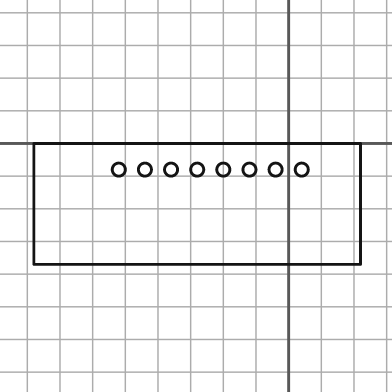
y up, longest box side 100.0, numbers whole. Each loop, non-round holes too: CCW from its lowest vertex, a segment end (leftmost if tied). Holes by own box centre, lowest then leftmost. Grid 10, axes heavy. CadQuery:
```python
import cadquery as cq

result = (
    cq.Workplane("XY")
    .moveTo(-78.0, -37.0)
    .lineTo(22.0, -37.0)
    .lineTo(22.0, 0.0)
    .lineTo(-78.0, 0.0)
    .close()
    .moveTo(-52.0, -8.0)
    .circle(2.0)
    .moveTo(-44.0, -8.0)
    .circle(2.0)
    .moveTo(-36.0, -8.0)
    .circle(2.0)
    .moveTo(-28.0, -8.0)
    .circle(2.0)
    .moveTo(-20.0, -8.0)
    .circle(2.0)
    .moveTo(-12.0, -8.0)
    .circle(2.0)
    .moveTo(-4.0, -8.0)
    .circle(2.0)
    .moveTo(4.0, -8.0)
    .circle(2.0)
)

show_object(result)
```